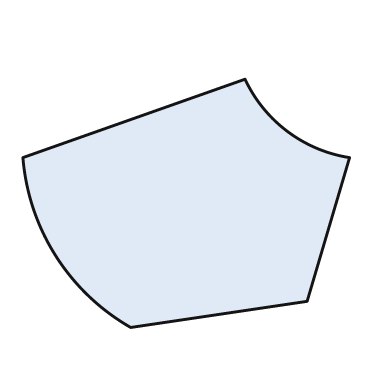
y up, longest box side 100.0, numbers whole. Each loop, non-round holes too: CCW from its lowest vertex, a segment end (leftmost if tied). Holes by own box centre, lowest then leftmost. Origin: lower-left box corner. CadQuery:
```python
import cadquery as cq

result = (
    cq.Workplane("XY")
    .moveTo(33.0, 0.0)
    .lineTo(87.0, 8.0)
    .lineTo(100.0, 52.0)
    .threePointArc((81.0, 60.0), (68.0, 76.0))
    .lineTo(0.0, 52.0)
    .threePointArc((10.0, 22.0), (33.0, 0.0))
    .close()
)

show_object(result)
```